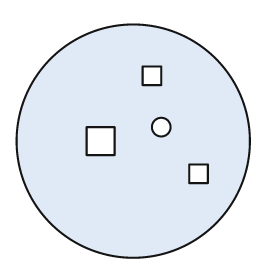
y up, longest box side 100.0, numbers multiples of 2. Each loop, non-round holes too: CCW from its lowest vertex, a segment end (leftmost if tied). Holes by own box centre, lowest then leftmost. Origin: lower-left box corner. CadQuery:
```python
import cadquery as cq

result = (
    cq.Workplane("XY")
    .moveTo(50.0, 50.0)
    .circle(50.0)
    .moveTo(74.0, 32.0)
    .lineTo(82.0, 32.0)
    .lineTo(82.0, 40.0)
    .lineTo(74.0, 40.0)
    .close()
    .moveTo(30.0, 44.0)
    .lineTo(42.0, 44.0)
    .lineTo(42.0, 56.0)
    .lineTo(30.0, 56.0)
    .close()
    .moveTo(62.0, 56.0)
    .circle(4.0)
    .moveTo(54.0, 74.0)
    .lineTo(62.0, 74.0)
    .lineTo(62.0, 82.0)
    .lineTo(54.0, 82.0)
    .close()
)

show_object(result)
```